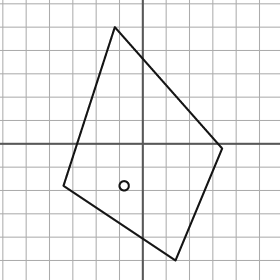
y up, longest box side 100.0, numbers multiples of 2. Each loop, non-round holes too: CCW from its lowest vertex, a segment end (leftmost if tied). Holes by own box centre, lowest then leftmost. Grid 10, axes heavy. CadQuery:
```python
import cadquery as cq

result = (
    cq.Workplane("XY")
    .moveTo(14.0, -50.0)
    .lineTo(34.0, -2.0)
    .lineTo(-12.0, 50.0)
    .lineTo(-34.0, -18.0)
    .close()
    .moveTo(-8.0, -18.0)
    .circle(2.0)
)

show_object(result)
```